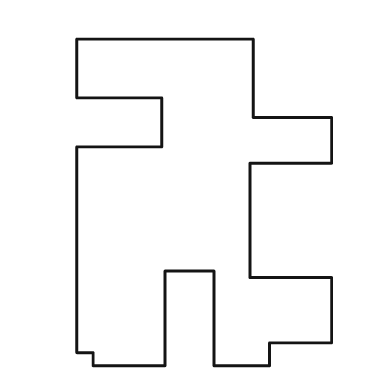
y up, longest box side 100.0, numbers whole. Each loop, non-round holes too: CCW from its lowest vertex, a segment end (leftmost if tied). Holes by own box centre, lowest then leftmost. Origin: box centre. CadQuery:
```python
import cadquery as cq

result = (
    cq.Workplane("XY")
    .moveTo(-34.0, -50.0)
    .lineTo(-12.0, -50.0)
    .lineTo(-12.0, -21.0)
    .lineTo(3.0, -21.0)
    .lineTo(3.0, -50.0)
    .lineTo(20.0, -50.0)
    .lineTo(20.0, -43.0)
    .lineTo(39.0, -43.0)
    .lineTo(39.0, -23.0)
    .lineTo(14.0, -23.0)
    .lineTo(14.0, 12.0)
    .lineTo(39.0, 12.0)
    .lineTo(39.0, 26.0)
    .lineTo(15.0, 26.0)
    .lineTo(15.0, 50.0)
    .lineTo(-39.0, 50.0)
    .lineTo(-39.0, 32.0)
    .lineTo(-13.0, 32.0)
    .lineTo(-13.0, 17.0)
    .lineTo(-39.0, 17.0)
    .lineTo(-39.0, -46.0)
    .lineTo(-34.0, -46.0)
    .close()
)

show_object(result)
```